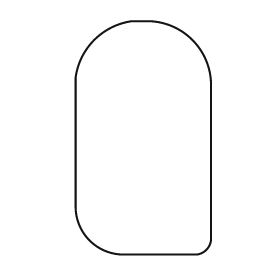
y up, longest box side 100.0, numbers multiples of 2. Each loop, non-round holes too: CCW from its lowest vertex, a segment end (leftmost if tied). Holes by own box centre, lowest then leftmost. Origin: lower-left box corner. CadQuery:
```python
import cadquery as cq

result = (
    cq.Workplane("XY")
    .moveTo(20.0, 0.0)
    .lineTo(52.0, 0.0)
    .threePointArc((56.0, 2.0), (58.0, 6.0))
    .lineTo(58.0, 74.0)
    .threePointArc((50.0, 92.0), (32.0, 100.0))
    .lineTo(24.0, 100.0)
    .threePointArc((8.0, 92.0), (0.0, 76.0))
    .lineTo(0.0, 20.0)
    .threePointArc((6.0, 6.0), (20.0, 0.0))
    .close()
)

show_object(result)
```